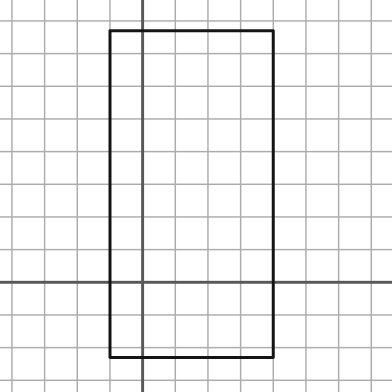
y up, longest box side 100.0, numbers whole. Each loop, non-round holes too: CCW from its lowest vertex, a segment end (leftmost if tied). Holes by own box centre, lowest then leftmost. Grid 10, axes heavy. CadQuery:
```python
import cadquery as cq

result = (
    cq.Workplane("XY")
    .moveTo(-10.0, -23.0)
    .lineTo(40.0, -23.0)
    .lineTo(40.0, 77.0)
    .lineTo(-10.0, 77.0)
    .close()
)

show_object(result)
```